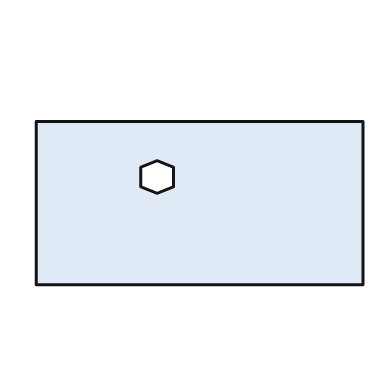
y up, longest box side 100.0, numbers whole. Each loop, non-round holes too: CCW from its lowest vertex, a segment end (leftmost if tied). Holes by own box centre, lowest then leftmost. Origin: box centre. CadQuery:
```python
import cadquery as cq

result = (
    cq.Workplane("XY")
    .moveTo(-50.0, -25.0)
    .lineTo(50.0, -25.0)
    .lineTo(50.0, 25.0)
    .lineTo(-50.0, 25.0)
    .close()
    .moveTo(-13.0, 3.0)
    .lineTo(-8.0, 5.0)
    .lineTo(-8.0, 11.0)
    .lineTo(-13.0, 13.0)
    .lineTo(-18.0, 11.0)
    .lineTo(-18.0, 5.0)
    .close()
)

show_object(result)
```